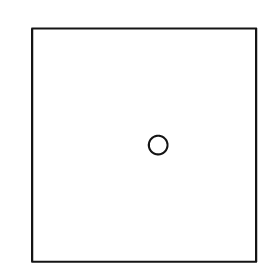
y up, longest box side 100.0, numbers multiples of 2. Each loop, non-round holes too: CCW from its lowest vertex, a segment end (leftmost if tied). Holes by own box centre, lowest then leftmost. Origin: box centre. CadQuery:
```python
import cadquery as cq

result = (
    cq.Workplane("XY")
    .moveTo(-48.0, -50.0)
    .lineTo(48.0, -50.0)
    .lineTo(48.0, 50.0)
    .lineTo(-48.0, 50.0)
    .close()
    .moveTo(6.0, 0.0)
    .circle(4.0)
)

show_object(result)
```